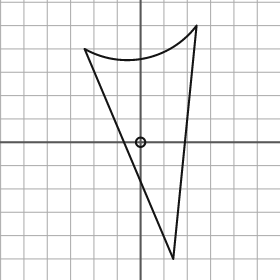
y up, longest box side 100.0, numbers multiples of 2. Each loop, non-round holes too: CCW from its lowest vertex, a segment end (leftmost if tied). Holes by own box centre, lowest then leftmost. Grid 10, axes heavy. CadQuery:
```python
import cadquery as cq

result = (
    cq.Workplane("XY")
    .moveTo(14.0, -50.0)
    .lineTo(24.0, 50.0)
    .threePointArc((2.0, 36.0), (-24.0, 40.0))
    .close()
    .moveTo(0.0, 0.0)
    .circle(2.0)
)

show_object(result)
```